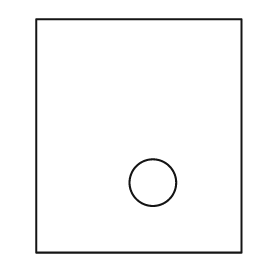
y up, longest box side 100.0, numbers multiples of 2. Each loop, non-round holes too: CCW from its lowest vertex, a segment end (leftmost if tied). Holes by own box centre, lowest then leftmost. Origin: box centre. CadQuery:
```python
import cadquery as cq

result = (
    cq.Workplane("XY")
    .moveTo(-44.0, -50.0)
    .lineTo(44.0, -50.0)
    .lineTo(44.0, 50.0)
    .lineTo(-44.0, 50.0)
    .close()
    .moveTo(6.0, -20.0)
    .circle(10.0)
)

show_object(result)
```